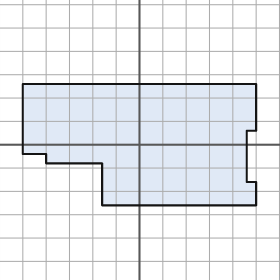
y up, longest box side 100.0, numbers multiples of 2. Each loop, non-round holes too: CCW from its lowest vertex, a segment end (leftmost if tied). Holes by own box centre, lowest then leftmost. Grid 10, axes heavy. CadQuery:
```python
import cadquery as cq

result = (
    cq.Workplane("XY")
    .moveTo(-16.0, -26.0)
    .lineTo(50.0, -26.0)
    .lineTo(50.0, -16.0)
    .lineTo(46.0, -16.0)
    .lineTo(46.0, 6.0)
    .lineTo(50.0, 6.0)
    .lineTo(50.0, 26.0)
    .lineTo(-50.0, 26.0)
    .lineTo(-50.0, -4.0)
    .lineTo(-40.0, -4.0)
    .lineTo(-40.0, -8.0)
    .lineTo(-16.0, -8.0)
    .close()
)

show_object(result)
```